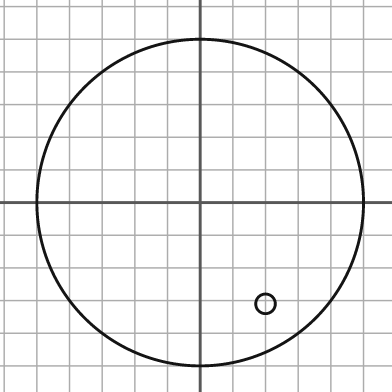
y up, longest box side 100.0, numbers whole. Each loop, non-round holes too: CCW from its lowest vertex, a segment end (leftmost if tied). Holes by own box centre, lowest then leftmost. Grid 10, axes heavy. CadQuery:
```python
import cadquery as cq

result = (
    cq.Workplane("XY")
    .moveTo(0.0, 0.0)
    .circle(50.0)
    .moveTo(20.0, -31.0)
    .circle(3.0)
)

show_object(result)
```